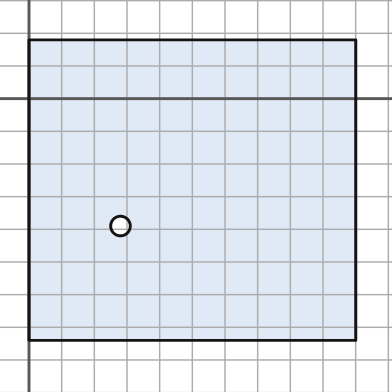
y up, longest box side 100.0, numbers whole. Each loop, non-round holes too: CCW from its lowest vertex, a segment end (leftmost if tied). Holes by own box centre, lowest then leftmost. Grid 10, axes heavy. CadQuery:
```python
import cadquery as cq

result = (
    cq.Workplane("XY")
    .moveTo(0.0, -74.0)
    .lineTo(100.0, -74.0)
    .lineTo(100.0, 18.0)
    .lineTo(0.0, 18.0)
    .close()
    .moveTo(28.0, -39.0)
    .circle(3.0)
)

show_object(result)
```